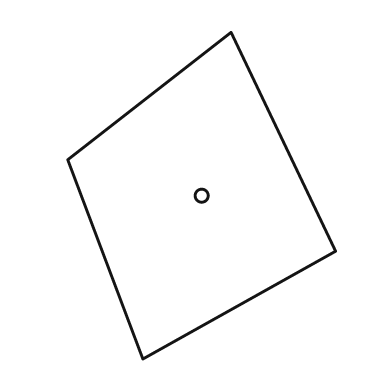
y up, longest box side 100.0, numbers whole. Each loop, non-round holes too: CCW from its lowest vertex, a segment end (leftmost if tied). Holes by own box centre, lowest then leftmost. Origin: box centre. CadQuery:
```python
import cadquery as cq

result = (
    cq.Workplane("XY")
    .moveTo(-18.0, -50.0)
    .lineTo(41.0, -17.0)
    .lineTo(9.0, 50.0)
    .lineTo(-41.0, 11.0)
    .close()
    .moveTo(0.0, 0.0)
    .circle(2.0)
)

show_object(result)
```